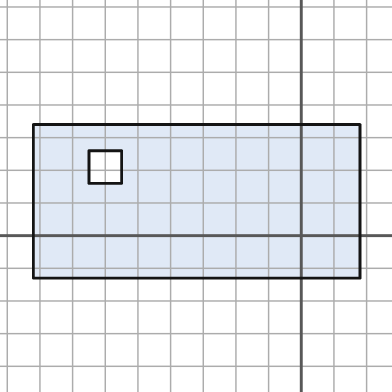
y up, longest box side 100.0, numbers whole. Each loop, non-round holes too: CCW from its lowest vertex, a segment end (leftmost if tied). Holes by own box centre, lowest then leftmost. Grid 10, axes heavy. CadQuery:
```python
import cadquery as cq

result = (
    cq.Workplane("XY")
    .moveTo(-82.0, -13.0)
    .lineTo(18.0, -13.0)
    .lineTo(18.0, 34.0)
    .lineTo(-82.0, 34.0)
    .close()
    .moveTo(-65.0, 16.0)
    .lineTo(-55.0, 16.0)
    .lineTo(-55.0, 26.0)
    .lineTo(-65.0, 26.0)
    .close()
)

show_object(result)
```